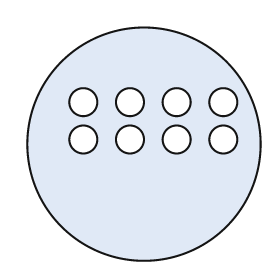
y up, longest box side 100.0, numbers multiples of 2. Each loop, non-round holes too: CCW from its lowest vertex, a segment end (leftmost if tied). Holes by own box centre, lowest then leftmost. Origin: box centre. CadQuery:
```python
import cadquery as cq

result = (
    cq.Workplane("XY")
    .moveTo(0.0, 0.0)
    .circle(50.0)
    .moveTo(-26.0, 2.0)
    .circle(6.0)
    .moveTo(-6.0, 2.0)
    .circle(6.0)
    .moveTo(14.0, 2.0)
    .circle(6.0)
    .moveTo(34.0, 2.0)
    .circle(6.0)
    .moveTo(-26.0, 18.0)
    .circle(6.0)
    .moveTo(-6.0, 18.0)
    .circle(6.0)
    .moveTo(14.0, 18.0)
    .circle(6.0)
    .moveTo(34.0, 18.0)
    .circle(6.0)
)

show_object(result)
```